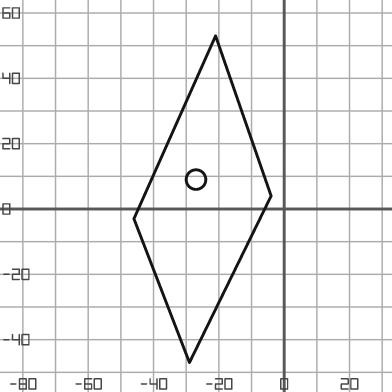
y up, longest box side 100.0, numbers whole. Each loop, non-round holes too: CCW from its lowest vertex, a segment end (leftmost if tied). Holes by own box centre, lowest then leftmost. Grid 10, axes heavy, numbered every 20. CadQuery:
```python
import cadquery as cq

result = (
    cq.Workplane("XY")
    .moveTo(-29.0, -47.0)
    .lineTo(-4.0, 4.0)
    .lineTo(-21.0, 53.0)
    .lineTo(-46.0, -3.0)
    .close()
    .moveTo(-27.0, 9.0)
    .circle(3.0)
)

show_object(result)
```